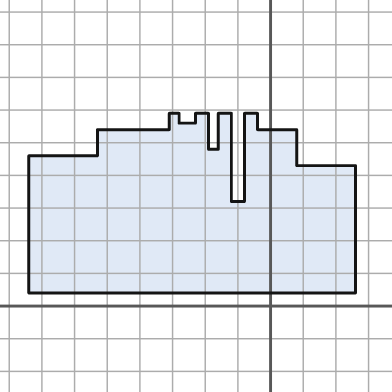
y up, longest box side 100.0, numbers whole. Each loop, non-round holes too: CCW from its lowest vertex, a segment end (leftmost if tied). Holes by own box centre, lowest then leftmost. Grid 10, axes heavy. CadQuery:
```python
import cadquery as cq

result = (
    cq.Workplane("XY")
    .moveTo(-74.0, 4.0)
    .lineTo(26.0, 4.0)
    .lineTo(26.0, 43.0)
    .lineTo(8.0, 43.0)
    .lineTo(8.0, 54.0)
    .lineTo(-4.0, 54.0)
    .lineTo(-4.0, 59.0)
    .lineTo(-8.0, 59.0)
    .lineTo(-8.0, 32.0)
    .lineTo(-12.0, 32.0)
    .lineTo(-12.0, 59.0)
    .lineTo(-16.0, 59.0)
    .lineTo(-16.0, 48.0)
    .lineTo(-19.0, 48.0)
    .lineTo(-19.0, 59.0)
    .lineTo(-23.0, 59.0)
    .lineTo(-23.0, 56.0)
    .lineTo(-28.0, 56.0)
    .lineTo(-28.0, 59.0)
    .lineTo(-31.0, 59.0)
    .lineTo(-31.0, 54.0)
    .lineTo(-53.0, 54.0)
    .lineTo(-53.0, 46.0)
    .lineTo(-74.0, 46.0)
    .close()
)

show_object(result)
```